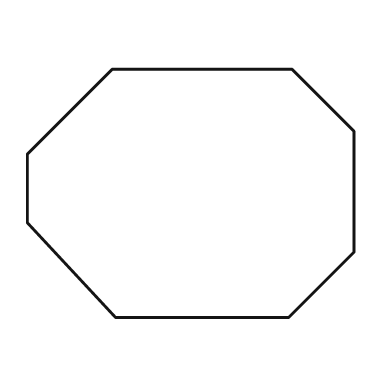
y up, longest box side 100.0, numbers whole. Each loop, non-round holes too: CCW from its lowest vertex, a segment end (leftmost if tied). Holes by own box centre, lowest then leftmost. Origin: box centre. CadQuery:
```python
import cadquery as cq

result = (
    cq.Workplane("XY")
    .moveTo(-23.0, -38.0)
    .lineTo(30.0, -38.0)
    .lineTo(50.0, -18.0)
    .lineTo(50.0, 19.0)
    .lineTo(31.0, 38.0)
    .lineTo(-24.0, 38.0)
    .lineTo(-50.0, 12.0)
    .lineTo(-50.0, -9.0)
    .close()
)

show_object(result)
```